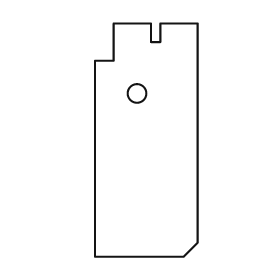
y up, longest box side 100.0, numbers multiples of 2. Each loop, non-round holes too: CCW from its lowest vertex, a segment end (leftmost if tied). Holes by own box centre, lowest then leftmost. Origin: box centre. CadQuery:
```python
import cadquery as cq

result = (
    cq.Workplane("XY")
    .moveTo(-22.0, -50.0)
    .lineTo(16.0, -50.0)
    .lineTo(22.0, -44.0)
    .lineTo(22.0, 50.0)
    .lineTo(6.0, 50.0)
    .lineTo(6.0, 42.0)
    .lineTo(2.0, 42.0)
    .lineTo(2.0, 50.0)
    .lineTo(-14.0, 50.0)
    .lineTo(-14.0, 34.0)
    .lineTo(-22.0, 34.0)
    .close()
    .moveTo(-4.0, 20.0)
    .circle(4.0)
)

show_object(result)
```